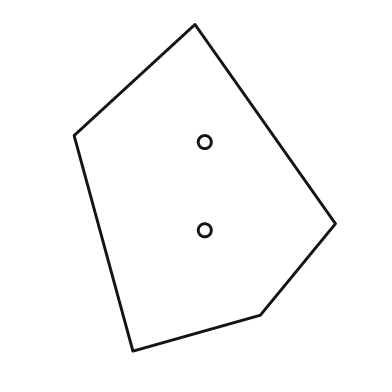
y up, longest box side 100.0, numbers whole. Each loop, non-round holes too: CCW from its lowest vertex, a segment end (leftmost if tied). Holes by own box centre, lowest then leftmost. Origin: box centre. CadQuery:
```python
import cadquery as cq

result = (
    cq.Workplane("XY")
    .moveTo(-22.0, -50.0)
    .lineTo(17.0, -39.0)
    .lineTo(40.0, -11.0)
    .lineTo(-3.0, 50.0)
    .lineTo(-40.0, 16.0)
    .close()
    .moveTo(0.0, -13.0)
    .circle(2.0)
    .moveTo(0.0, 14.0)
    .circle(2.0)
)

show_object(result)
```